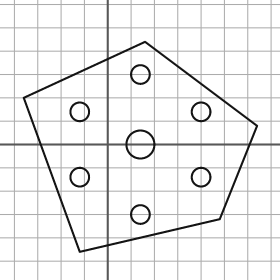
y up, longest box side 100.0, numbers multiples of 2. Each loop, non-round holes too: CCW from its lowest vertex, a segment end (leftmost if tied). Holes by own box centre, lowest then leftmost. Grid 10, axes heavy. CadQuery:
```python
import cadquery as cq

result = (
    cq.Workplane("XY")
    .moveTo(-12.0, -46.0)
    .lineTo(48.0, -32.0)
    .lineTo(64.0, 8.0)
    .lineTo(16.0, 44.0)
    .lineTo(-36.0, 20.0)
    .close()
    .moveTo(14.0, -30.0)
    .circle(4.0)
    .moveTo(-12.0, -14.0)
    .circle(4.0)
    .moveTo(40.0, -14.0)
    .circle(4.0)
    .moveTo(14.0, 0.0)
    .circle(6.0)
    .moveTo(-12.0, 14.0)
    .circle(4.0)
    .moveTo(40.0, 14.0)
    .circle(4.0)
    .moveTo(14.0, 30.0)
    .circle(4.0)
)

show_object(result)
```